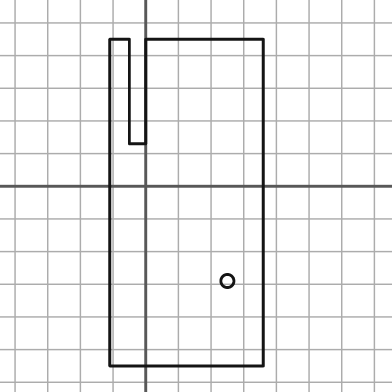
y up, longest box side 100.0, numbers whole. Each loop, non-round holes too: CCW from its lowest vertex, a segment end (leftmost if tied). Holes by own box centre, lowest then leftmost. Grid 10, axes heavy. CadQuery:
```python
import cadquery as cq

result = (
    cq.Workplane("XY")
    .moveTo(-11.0, -55.0)
    .lineTo(36.0, -55.0)
    .lineTo(36.0, 45.0)
    .lineTo(0.0, 45.0)
    .lineTo(0.0, 13.0)
    .lineTo(-5.0, 13.0)
    .lineTo(-5.0, 45.0)
    .lineTo(-11.0, 45.0)
    .close()
    .moveTo(25.0, -29.0)
    .circle(2.0)
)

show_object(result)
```